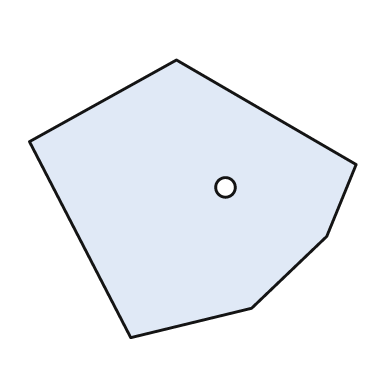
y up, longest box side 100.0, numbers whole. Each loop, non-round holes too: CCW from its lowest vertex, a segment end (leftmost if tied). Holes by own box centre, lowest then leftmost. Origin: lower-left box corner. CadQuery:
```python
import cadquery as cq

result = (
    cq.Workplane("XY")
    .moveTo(31.0, 0.0)
    .lineTo(68.0, 9.0)
    .lineTo(91.0, 31.0)
    .lineTo(100.0, 53.0)
    .lineTo(45.0, 85.0)
    .lineTo(0.0, 60.0)
    .close()
    .moveTo(60.0, 46.0)
    .circle(3.0)
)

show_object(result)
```